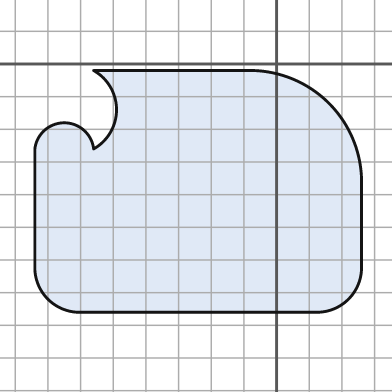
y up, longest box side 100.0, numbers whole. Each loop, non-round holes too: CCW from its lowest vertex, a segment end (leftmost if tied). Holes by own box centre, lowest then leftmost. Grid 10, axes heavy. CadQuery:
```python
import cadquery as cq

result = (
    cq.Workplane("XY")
    .moveTo(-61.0, -76.0)
    .lineTo(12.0, -76.0)
    .threePointArc((22.0, -72.0), (26.0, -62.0))
    .lineTo(26.0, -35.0)
    .threePointArc((16.0, -12.0), (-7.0, -2.0))
    .lineTo(-56.0, -2.0)
    .threePointArc((-49.0, -14.0), (-56.0, -26.0))
    .threePointArc((-65.0, -18.0), (-74.0, -26.0))
    .lineTo(-74.0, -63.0)
    .threePointArc((-70.0, -72.0), (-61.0, -76.0))
    .close()
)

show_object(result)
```